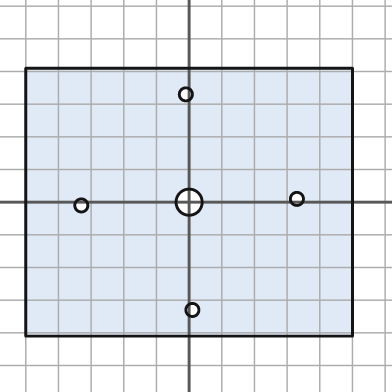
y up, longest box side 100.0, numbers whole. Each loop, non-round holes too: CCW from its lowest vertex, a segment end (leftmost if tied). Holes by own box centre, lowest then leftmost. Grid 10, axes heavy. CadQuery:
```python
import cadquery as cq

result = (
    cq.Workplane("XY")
    .moveTo(-50.0, -41.0)
    .lineTo(50.0, -41.0)
    .lineTo(50.0, 41.0)
    .lineTo(-50.0, 41.0)
    .close()
    .moveTo(1.0, -33.0)
    .circle(2.0)
    .moveTo(-33.0, -1.0)
    .circle(2.0)
    .moveTo(0.0, 0.0)
    .circle(4.0)
    .moveTo(33.0, 1.0)
    .circle(2.0)
    .moveTo(-1.0, 33.0)
    .circle(2.0)
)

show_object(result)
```